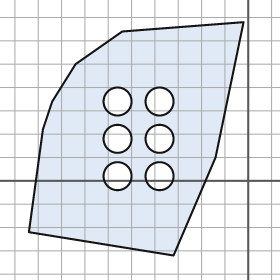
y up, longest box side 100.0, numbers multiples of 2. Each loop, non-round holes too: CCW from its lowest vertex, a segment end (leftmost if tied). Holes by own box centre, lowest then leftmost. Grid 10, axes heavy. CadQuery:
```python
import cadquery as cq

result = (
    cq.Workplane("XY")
    .moveTo(-32.0, -32.0)
    .lineTo(-14.0, 10.0)
    .lineTo(-2.0, 68.0)
    .lineTo(-54.0, 64.0)
    .lineTo(-74.0, 50.0)
    .lineTo(-84.0, 34.0)
    .lineTo(-88.0, 22.0)
    .lineTo(-94.0, -22.0)
    .close()
    .moveTo(-56.0, 2.0)
    .circle(6.0)
    .moveTo(-38.0, 2.0)
    .circle(6.0)
    .moveTo(-56.0, 18.0)
    .circle(6.0)
    .moveTo(-38.0, 18.0)
    .circle(6.0)
    .moveTo(-56.0, 34.0)
    .circle(6.0)
    .moveTo(-38.0, 34.0)
    .circle(6.0)
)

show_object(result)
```